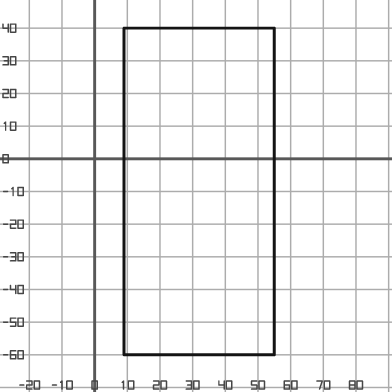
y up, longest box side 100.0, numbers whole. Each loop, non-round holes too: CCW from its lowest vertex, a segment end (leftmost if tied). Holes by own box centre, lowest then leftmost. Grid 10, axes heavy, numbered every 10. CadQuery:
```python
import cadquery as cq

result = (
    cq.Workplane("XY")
    .moveTo(9.0, -60.0)
    .lineTo(55.0, -60.0)
    .lineTo(55.0, 40.0)
    .lineTo(9.0, 40.0)
    .close()
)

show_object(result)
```